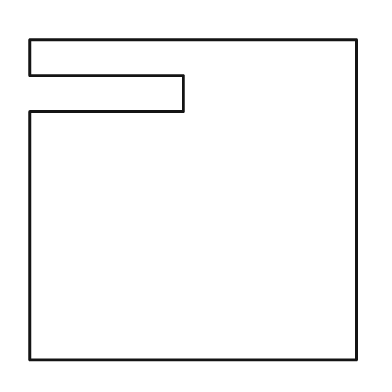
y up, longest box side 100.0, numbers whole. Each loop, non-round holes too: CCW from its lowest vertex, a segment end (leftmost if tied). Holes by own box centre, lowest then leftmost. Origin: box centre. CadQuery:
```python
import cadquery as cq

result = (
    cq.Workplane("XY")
    .moveTo(-50.0, -49.0)
    .lineTo(50.0, -49.0)
    .lineTo(50.0, 49.0)
    .lineTo(-50.0, 49.0)
    .lineTo(-50.0, 38.0)
    .lineTo(-3.0, 38.0)
    .lineTo(-3.0, 27.0)
    .lineTo(-50.0, 27.0)
    .close()
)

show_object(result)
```